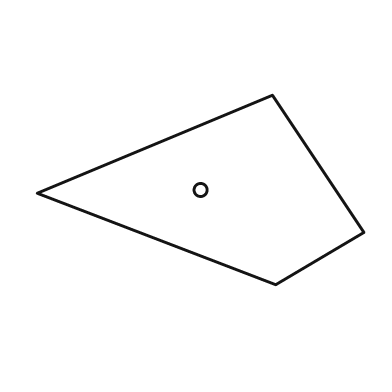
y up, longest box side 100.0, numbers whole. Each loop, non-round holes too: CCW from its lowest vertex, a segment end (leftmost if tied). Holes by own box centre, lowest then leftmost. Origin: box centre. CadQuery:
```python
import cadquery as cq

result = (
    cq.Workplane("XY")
    .moveTo(23.0, -29.0)
    .lineTo(50.0, -13.0)
    .lineTo(22.0, 29.0)
    .lineTo(-50.0, -1.0)
    .close()
    .moveTo(0.0, 0.0)
    .circle(2.0)
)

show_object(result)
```